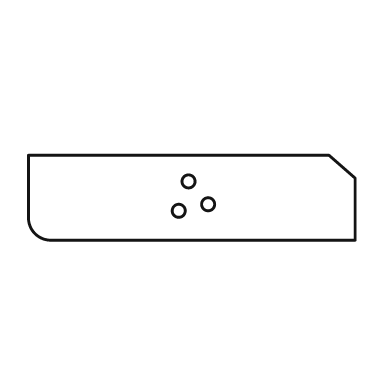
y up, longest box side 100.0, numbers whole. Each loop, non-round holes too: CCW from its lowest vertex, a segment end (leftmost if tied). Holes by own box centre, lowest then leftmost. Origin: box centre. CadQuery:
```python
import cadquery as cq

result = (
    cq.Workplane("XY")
    .moveTo(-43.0, -13.0)
    .lineTo(50.0, -13.0)
    .lineTo(50.0, 6.0)
    .lineTo(42.0, 13.0)
    .lineTo(-50.0, 13.0)
    .lineTo(-50.0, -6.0)
    .threePointArc((-48.0, -11.0), (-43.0, -13.0))
    .close()
    .moveTo(-4.0, -4.0)
    .circle(2.0)
    .moveTo(5.0, -2.0)
    .circle(2.0)
    .moveTo(-1.0, 5.0)
    .circle(2.0)
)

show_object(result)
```